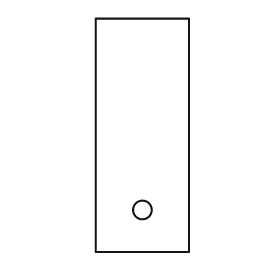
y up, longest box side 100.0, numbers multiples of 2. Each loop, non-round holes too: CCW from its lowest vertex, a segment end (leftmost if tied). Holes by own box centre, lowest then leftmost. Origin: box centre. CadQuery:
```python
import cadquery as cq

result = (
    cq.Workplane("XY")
    .moveTo(-20.0, -50.0)
    .lineTo(20.0, -50.0)
    .lineTo(20.0, 50.0)
    .lineTo(-20.0, 50.0)
    .close()
    .moveTo(0.0, -32.0)
    .circle(4.0)
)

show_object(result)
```